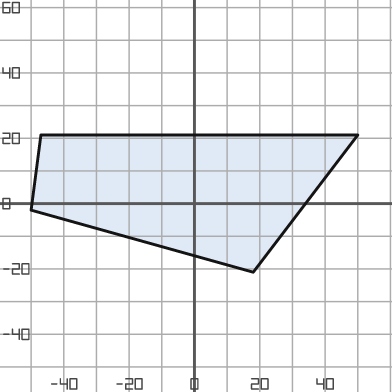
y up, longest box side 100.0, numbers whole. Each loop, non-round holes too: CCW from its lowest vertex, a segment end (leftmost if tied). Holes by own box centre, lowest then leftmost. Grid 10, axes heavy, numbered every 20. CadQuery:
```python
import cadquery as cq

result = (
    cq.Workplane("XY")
    .moveTo(18.0, -21.0)
    .lineTo(50.0, 21.0)
    .lineTo(-47.0, 21.0)
    .lineTo(-50.0, -2.0)
    .close()
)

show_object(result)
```